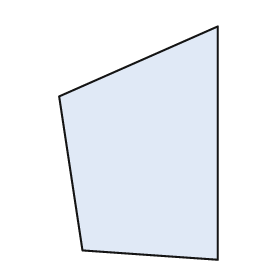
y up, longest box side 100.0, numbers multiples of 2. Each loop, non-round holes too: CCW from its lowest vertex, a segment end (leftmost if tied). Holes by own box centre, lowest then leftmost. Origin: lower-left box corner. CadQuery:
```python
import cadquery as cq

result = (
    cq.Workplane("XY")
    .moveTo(68.0, 0.0)
    .lineTo(68.0, 100.0)
    .lineTo(0.0, 70.0)
    .lineTo(10.0, 4.0)
    .close()
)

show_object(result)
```